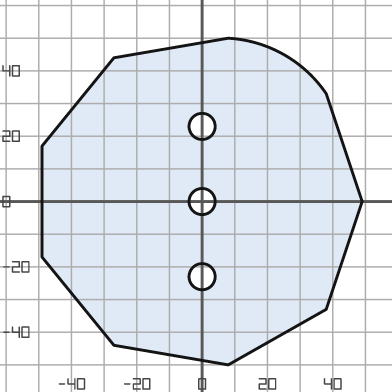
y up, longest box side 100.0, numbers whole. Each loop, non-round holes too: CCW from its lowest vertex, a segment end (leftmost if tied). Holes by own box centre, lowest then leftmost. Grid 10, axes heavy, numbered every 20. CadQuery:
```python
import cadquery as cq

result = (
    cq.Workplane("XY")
    .moveTo(8.0, -50.0)
    .lineTo(38.0, -33.0)
    .lineTo(49.0, 0.0)
    .lineTo(38.0, 33.0)
    .threePointArc((25.0, 45.0), (8.0, 50.0))
    .lineTo(-27.0, 44.0)
    .lineTo(-49.0, 17.0)
    .lineTo(-49.0, -17.0)
    .lineTo(-27.0, -44.0)
    .close()
    .moveTo(0.0, -23.0)
    .circle(4.0)
    .moveTo(0.0, 0.0)
    .circle(4.0)
    .moveTo(0.0, 23.0)
    .circle(4.0)
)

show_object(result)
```